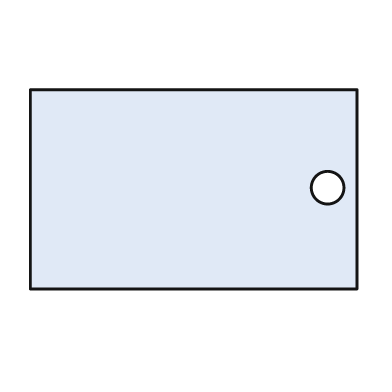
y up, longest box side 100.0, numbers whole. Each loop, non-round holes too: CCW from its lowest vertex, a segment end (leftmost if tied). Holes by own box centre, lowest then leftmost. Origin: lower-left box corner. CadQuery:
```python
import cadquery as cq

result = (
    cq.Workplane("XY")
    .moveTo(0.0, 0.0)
    .lineTo(100.0, 0.0)
    .lineTo(100.0, 61.0)
    .lineTo(0.0, 61.0)
    .close()
    .moveTo(91.0, 31.0)
    .circle(5.0)
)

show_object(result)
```